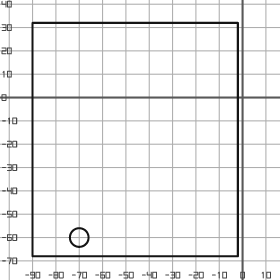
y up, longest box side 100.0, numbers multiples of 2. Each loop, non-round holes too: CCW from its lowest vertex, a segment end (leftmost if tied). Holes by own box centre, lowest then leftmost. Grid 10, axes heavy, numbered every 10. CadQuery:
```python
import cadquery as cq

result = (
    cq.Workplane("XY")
    .moveTo(-90.0, -68.0)
    .lineTo(-2.0, -68.0)
    .lineTo(-2.0, 32.0)
    .lineTo(-90.0, 32.0)
    .close()
    .moveTo(-70.0, -60.0)
    .circle(4.0)
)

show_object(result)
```